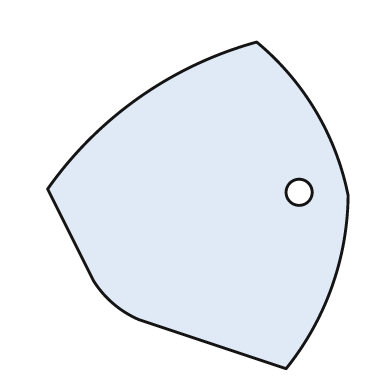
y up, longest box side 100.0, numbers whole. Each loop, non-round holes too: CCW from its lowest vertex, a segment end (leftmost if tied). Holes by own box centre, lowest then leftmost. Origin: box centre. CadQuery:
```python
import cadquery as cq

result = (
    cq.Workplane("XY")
    .moveTo(27.0, -50.0)
    .threePointArc((41.0, -25.0), (46.0, 3.0))
    .threePointArc((36.0, 29.0), (18.0, 50.0))
    .threePointArc((-18.0, 33.0), (-46.0, 5.0))
    .lineTo(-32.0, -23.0)
    .threePointArc((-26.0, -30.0), (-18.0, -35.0))
    .close()
    .moveTo(31.0, 4.0)
    .circle(4.0)
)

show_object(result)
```